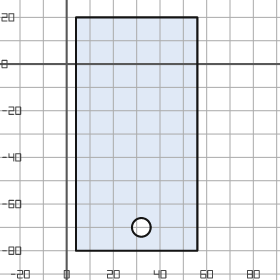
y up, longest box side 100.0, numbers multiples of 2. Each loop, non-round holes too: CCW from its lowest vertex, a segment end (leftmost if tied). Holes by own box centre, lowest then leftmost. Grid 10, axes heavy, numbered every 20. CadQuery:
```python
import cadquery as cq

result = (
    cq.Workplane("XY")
    .moveTo(4.0, -80.0)
    .lineTo(56.0, -80.0)
    .lineTo(56.0, 20.0)
    .lineTo(4.0, 20.0)
    .close()
    .moveTo(32.0, -70.0)
    .circle(4.0)
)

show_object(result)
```